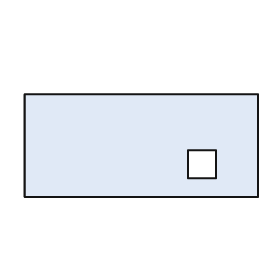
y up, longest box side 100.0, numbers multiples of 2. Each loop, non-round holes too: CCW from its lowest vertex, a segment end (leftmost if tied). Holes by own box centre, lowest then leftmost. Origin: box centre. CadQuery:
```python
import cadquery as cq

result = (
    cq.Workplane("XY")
    .moveTo(-50.0, -22.0)
    .lineTo(50.0, -22.0)
    .lineTo(50.0, 22.0)
    .lineTo(-50.0, 22.0)
    .close()
    .moveTo(20.0, -14.0)
    .lineTo(32.0, -14.0)
    .lineTo(32.0, -2.0)
    .lineTo(20.0, -2.0)
    .close()
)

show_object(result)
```